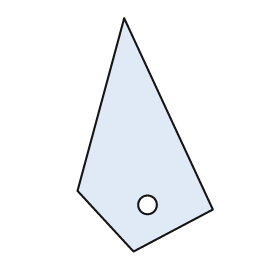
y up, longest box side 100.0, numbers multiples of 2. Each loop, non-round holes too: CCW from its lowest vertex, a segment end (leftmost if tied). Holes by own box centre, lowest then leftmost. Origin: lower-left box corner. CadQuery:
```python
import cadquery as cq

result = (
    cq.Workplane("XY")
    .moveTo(24.0, 0.0)
    .lineTo(58.0, 18.0)
    .lineTo(20.0, 100.0)
    .lineTo(0.0, 26.0)
    .close()
    .moveTo(30.0, 20.0)
    .circle(4.0)
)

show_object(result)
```